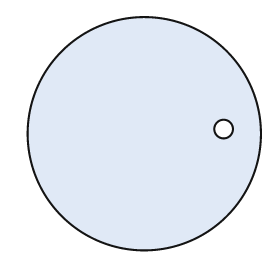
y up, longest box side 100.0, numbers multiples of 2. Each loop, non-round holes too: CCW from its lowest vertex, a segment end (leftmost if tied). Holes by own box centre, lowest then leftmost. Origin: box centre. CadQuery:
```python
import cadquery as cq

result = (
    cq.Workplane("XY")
    .moveTo(0.0, 0.0)
    .circle(50.0)
    .moveTo(34.0, 2.0)
    .circle(4.0)
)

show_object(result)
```